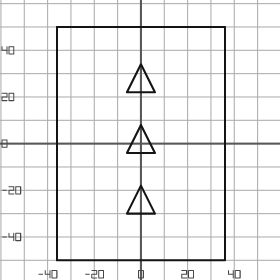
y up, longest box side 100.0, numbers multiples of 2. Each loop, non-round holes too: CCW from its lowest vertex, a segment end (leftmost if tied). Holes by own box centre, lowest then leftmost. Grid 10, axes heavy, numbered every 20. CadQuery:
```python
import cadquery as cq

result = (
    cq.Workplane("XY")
    .moveTo(-36.0, -50.0)
    .lineTo(36.0, -50.0)
    .lineTo(36.0, 50.0)
    .lineTo(-36.0, 50.0)
    .close()
    .moveTo(-6.0, -30.0)
    .lineTo(6.0, -30.0)
    .lineTo(0.0, -18.0)
    .close()
    .moveTo(-6.0, -4.0)
    .lineTo(6.0, -4.0)
    .lineTo(0.0, 8.0)
    .close()
    .moveTo(-6.0, 22.0)
    .lineTo(6.0, 22.0)
    .lineTo(0.0, 34.0)
    .close()
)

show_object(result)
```